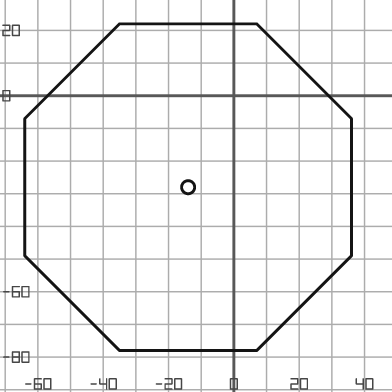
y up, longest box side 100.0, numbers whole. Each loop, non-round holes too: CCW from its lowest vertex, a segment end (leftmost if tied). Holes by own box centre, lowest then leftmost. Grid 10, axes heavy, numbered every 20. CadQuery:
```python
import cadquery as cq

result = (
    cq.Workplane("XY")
    .moveTo(-35.0, -78.0)
    .lineTo(7.0, -78.0)
    .lineTo(36.0, -49.0)
    .lineTo(36.0, -7.0)
    .lineTo(7.0, 22.0)
    .lineTo(-35.0, 22.0)
    .lineTo(-64.0, -7.0)
    .lineTo(-64.0, -49.0)
    .close()
    .moveTo(-14.0, -28.0)
    .circle(2.0)
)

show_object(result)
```